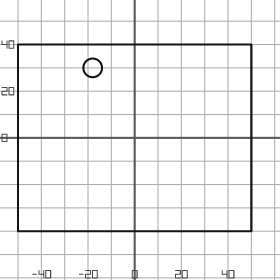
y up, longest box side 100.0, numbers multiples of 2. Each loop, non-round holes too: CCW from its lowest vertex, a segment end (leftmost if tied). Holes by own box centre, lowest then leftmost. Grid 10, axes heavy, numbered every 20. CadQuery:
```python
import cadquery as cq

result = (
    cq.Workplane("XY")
    .moveTo(-50.0, -40.0)
    .lineTo(50.0, -40.0)
    .lineTo(50.0, 40.0)
    .lineTo(-50.0, 40.0)
    .close()
    .moveTo(-18.0, 30.0)
    .circle(4.0)
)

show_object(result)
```